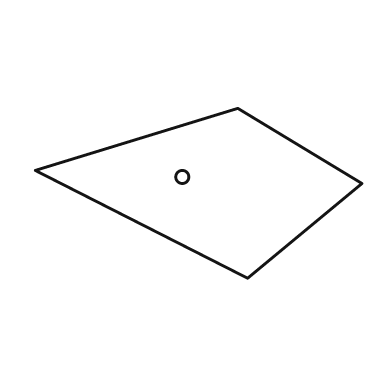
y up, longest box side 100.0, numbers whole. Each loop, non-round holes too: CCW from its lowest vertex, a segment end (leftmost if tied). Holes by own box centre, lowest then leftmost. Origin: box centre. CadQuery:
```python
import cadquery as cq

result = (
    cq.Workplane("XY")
    .moveTo(15.0, -26.0)
    .lineTo(50.0, 3.0)
    .lineTo(12.0, 26.0)
    .lineTo(-50.0, 7.0)
    .close()
    .moveTo(-5.0, 5.0)
    .circle(2.0)
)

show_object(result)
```